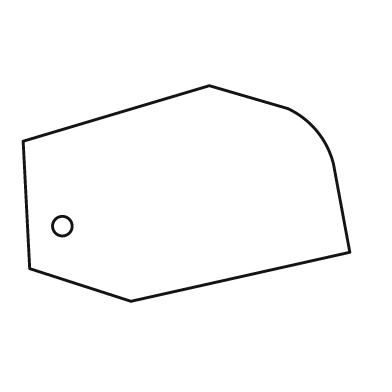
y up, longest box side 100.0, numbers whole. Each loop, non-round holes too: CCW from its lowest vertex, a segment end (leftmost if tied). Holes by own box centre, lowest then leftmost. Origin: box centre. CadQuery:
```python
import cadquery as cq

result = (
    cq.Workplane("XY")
    .moveTo(-17.0, -33.0)
    .lineTo(50.0, -18.0)
    .lineTo(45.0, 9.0)
    .threePointArc((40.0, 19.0), (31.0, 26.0))
    .lineTo(7.0, 33.0)
    .lineTo(-50.0, 16.0)
    .lineTo(-48.0, -23.0)
    .close()
    .moveTo(-38.0, -10.0)
    .circle(3.0)
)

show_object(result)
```